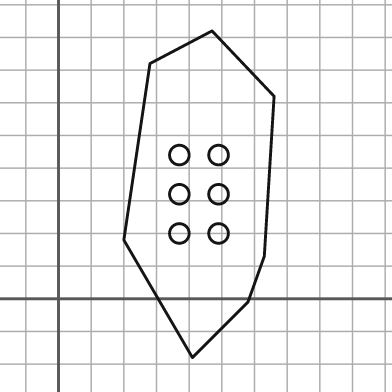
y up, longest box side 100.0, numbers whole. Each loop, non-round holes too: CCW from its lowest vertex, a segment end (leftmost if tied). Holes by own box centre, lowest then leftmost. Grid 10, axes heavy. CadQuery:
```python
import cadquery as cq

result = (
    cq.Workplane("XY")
    .moveTo(41.0, -18.0)
    .lineTo(58.0, -1.0)
    .lineTo(63.0, 13.0)
    .lineTo(66.0, 62.0)
    .lineTo(47.0, 82.0)
    .lineTo(28.0, 72.0)
    .lineTo(20.0, 18.0)
    .close()
    .moveTo(37.0, 20.0)
    .circle(3.0)
    .moveTo(49.0, 20.0)
    .circle(3.0)
    .moveTo(37.0, 32.0)
    .circle(3.0)
    .moveTo(49.0, 32.0)
    .circle(3.0)
    .moveTo(37.0, 44.0)
    .circle(3.0)
    .moveTo(49.0, 44.0)
    .circle(3.0)
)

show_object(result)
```